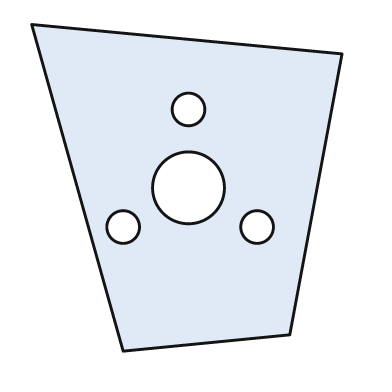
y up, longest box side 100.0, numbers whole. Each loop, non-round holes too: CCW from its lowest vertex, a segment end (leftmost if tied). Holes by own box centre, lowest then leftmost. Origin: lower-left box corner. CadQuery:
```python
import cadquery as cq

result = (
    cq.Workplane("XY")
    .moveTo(28.0, 0.0)
    .lineTo(79.0, 5.0)
    .lineTo(95.0, 91.0)
    .lineTo(0.0, 100.0)
    .close()
    .moveTo(28.0, 38.0)
    .circle(5.0)
    .moveTo(69.0, 38.0)
    .circle(5.0)
    .moveTo(48.0, 50.0)
    .circle(11.0)
    .moveTo(48.0, 74.0)
    .circle(5.0)
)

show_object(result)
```